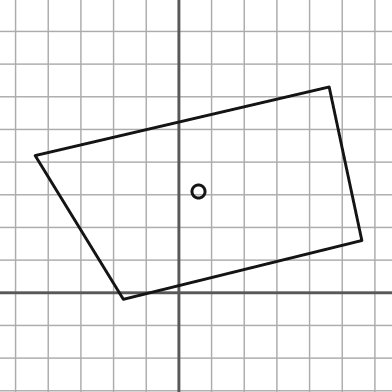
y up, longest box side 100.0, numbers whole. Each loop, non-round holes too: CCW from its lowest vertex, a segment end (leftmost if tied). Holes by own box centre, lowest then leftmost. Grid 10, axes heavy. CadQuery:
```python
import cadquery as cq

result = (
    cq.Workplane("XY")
    .moveTo(-17.0, -2.0)
    .lineTo(56.0, 16.0)
    .lineTo(46.0, 63.0)
    .lineTo(-44.0, 42.0)
    .close()
    .moveTo(6.0, 31.0)
    .circle(2.0)
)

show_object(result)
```